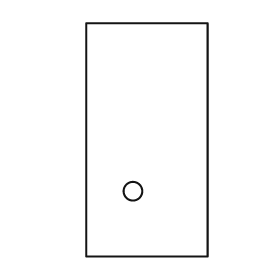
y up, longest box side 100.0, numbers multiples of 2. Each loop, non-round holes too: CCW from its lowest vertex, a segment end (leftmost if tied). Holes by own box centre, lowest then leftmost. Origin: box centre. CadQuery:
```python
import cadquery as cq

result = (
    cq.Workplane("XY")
    .moveTo(-26.0, -50.0)
    .lineTo(26.0, -50.0)
    .lineTo(26.0, 50.0)
    .lineTo(-26.0, 50.0)
    .close()
    .moveTo(-6.0, -22.0)
    .circle(4.0)
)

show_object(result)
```